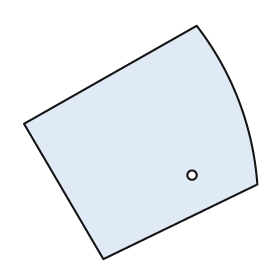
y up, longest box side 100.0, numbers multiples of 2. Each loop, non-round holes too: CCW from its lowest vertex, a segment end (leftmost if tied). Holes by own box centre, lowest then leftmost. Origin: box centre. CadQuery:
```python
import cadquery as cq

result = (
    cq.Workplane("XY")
    .moveTo(-16.0, -50.0)
    .lineTo(50.0, -18.0)
    .threePointArc((42.0, 18.0), (24.0, 50.0))
    .lineTo(-50.0, 8.0)
    .close()
    .moveTo(22.0, -14.0)
    .circle(2.0)
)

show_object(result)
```